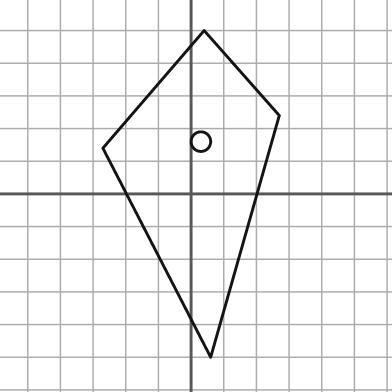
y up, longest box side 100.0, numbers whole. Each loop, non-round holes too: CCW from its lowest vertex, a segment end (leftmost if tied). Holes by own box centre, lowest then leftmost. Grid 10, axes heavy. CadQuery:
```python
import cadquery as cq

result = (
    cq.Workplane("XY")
    .moveTo(6.0, -50.0)
    .lineTo(27.0, 24.0)
    .lineTo(4.0, 50.0)
    .lineTo(-27.0, 14.0)
    .close()
    .moveTo(3.0, 16.0)
    .circle(3.0)
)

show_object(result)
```